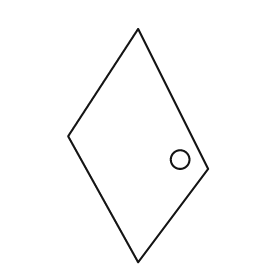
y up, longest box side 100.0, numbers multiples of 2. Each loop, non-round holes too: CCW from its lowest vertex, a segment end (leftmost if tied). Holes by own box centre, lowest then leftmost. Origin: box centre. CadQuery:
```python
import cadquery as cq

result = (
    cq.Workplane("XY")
    .moveTo(0.0, -50.0)
    .lineTo(30.0, -10.0)
    .lineTo(0.0, 50.0)
    .lineTo(-30.0, 4.0)
    .close()
    .moveTo(18.0, -6.0)
    .circle(4.0)
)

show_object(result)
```